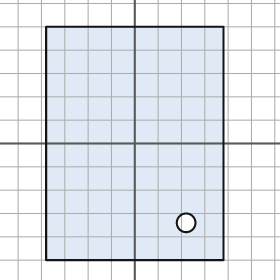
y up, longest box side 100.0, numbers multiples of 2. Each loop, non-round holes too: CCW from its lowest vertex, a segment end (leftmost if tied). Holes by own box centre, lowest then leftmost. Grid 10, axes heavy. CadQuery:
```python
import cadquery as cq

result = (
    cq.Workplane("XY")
    .moveTo(-38.0, -50.0)
    .lineTo(38.0, -50.0)
    .lineTo(38.0, 50.0)
    .lineTo(-38.0, 50.0)
    .close()
    .moveTo(22.0, -34.0)
    .circle(4.0)
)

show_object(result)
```